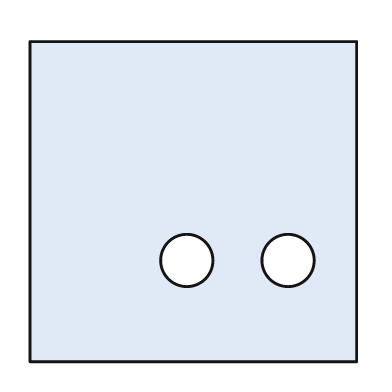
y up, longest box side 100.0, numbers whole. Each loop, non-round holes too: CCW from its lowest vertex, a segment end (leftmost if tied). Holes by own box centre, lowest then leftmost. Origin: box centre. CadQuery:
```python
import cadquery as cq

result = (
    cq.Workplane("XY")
    .moveTo(-50.0, -49.0)
    .lineTo(50.0, -49.0)
    .lineTo(50.0, 49.0)
    .lineTo(-50.0, 49.0)
    .close()
    .moveTo(-2.0, -18.0)
    .circle(8.0)
    .moveTo(29.0, -18.0)
    .circle(8.0)
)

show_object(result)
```